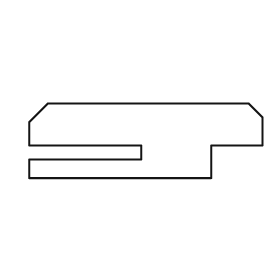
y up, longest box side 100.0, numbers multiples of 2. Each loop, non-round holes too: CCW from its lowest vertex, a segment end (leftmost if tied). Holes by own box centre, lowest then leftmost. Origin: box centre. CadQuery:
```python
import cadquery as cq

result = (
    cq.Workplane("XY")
    .moveTo(-50.0, -16.0)
    .lineTo(28.0, -16.0)
    .lineTo(28.0, -2.0)
    .lineTo(50.0, -2.0)
    .lineTo(50.0, 10.0)
    .lineTo(44.0, 16.0)
    .lineTo(-42.0, 16.0)
    .lineTo(-50.0, 8.0)
    .lineTo(-50.0, -2.0)
    .lineTo(-2.0, -2.0)
    .lineTo(-2.0, -8.0)
    .lineTo(-50.0, -8.0)
    .close()
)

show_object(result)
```